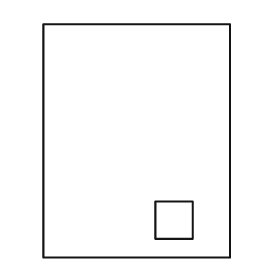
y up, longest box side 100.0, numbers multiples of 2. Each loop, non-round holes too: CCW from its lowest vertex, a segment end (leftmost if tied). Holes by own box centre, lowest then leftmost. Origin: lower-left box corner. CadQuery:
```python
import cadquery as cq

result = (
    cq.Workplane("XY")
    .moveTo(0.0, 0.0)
    .lineTo(80.0, 0.0)
    .lineTo(80.0, 100.0)
    .lineTo(0.0, 100.0)
    .close()
    .moveTo(48.0, 8.0)
    .lineTo(64.0, 8.0)
    .lineTo(64.0, 24.0)
    .lineTo(48.0, 24.0)
    .close()
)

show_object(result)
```